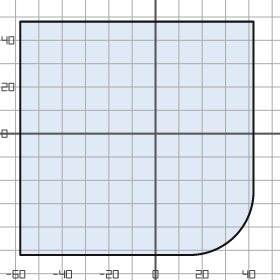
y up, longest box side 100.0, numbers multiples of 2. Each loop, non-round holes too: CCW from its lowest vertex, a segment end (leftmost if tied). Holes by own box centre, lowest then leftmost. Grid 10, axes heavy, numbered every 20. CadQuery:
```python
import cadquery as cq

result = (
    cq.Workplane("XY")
    .moveTo(-58.0, -52.0)
    .lineTo(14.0, -52.0)
    .threePointArc((34.0, -44.0), (42.0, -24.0))
    .lineTo(42.0, 48.0)
    .lineTo(-58.0, 48.0)
    .close()
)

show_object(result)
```